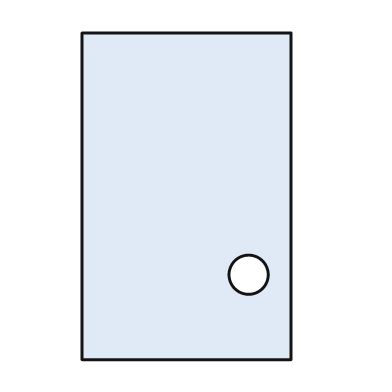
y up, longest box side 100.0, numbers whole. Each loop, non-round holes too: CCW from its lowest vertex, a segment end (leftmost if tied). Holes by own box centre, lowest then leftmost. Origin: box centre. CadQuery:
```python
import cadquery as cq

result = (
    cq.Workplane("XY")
    .moveTo(-32.0, -50.0)
    .lineTo(32.0, -50.0)
    .lineTo(32.0, 50.0)
    .lineTo(-32.0, 50.0)
    .close()
    .moveTo(19.0, -24.0)
    .circle(6.0)
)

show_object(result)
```